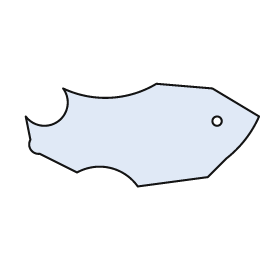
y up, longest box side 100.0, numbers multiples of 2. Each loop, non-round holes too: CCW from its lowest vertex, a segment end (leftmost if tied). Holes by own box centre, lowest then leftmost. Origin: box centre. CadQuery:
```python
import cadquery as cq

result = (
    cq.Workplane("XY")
    .moveTo(-2.0, -22.0)
    .lineTo(28.0, -18.0)
    .lineTo(36.0, -10.0)
    .threePointArc((44.0, -2.0), (50.0, 8.0))
    .lineTo(30.0, 20.0)
    .lineTo(6.0, 22.0)
    .threePointArc((-14.0, 16.0), (-34.0, 20.0))
    .threePointArc((-36.0, 6.0), (-50.0, 8.0))
    .lineTo(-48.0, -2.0)
    .threePointArc((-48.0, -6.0), (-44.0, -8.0))
    .lineTo(-28.0, -16.0)
    .threePointArc((-14.0, -14.0), (-2.0, -22.0))
    .close()
    .moveTo(32.0, 6.0)
    .circle(2.0)
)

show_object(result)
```